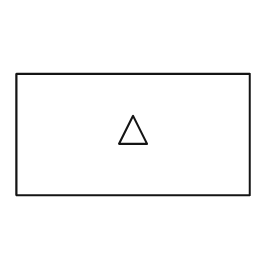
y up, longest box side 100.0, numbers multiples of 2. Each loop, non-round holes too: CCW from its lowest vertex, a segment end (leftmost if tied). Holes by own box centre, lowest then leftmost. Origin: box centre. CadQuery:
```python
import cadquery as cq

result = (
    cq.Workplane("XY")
    .moveTo(-50.0, -26.0)
    .lineTo(50.0, -26.0)
    .lineTo(50.0, 26.0)
    .lineTo(-50.0, 26.0)
    .close()
    .moveTo(-6.0, -4.0)
    .lineTo(6.0, -4.0)
    .lineTo(0.0, 8.0)
    .close()
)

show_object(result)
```